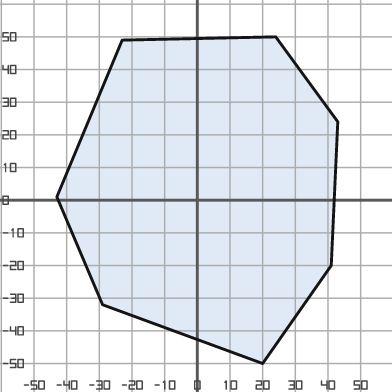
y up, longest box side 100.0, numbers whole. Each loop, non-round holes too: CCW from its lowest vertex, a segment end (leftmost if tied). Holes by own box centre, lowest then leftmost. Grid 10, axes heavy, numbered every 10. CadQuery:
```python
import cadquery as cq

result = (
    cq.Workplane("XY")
    .moveTo(20.0, -50.0)
    .lineTo(41.0, -20.0)
    .lineTo(43.0, 24.0)
    .lineTo(24.0, 50.0)
    .lineTo(-23.0, 49.0)
    .lineTo(-43.0, 1.0)
    .lineTo(-29.0, -32.0)
    .close()
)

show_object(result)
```